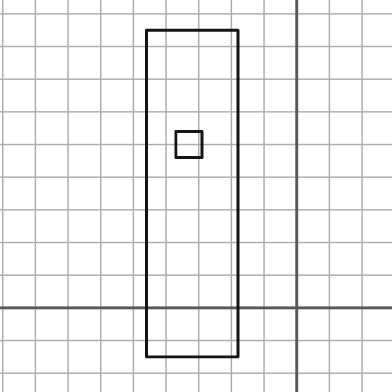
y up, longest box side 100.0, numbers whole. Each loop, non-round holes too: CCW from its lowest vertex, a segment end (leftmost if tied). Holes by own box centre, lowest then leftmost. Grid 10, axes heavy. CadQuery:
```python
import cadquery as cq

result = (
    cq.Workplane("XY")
    .moveTo(-46.0, -15.0)
    .lineTo(-18.0, -15.0)
    .lineTo(-18.0, 85.0)
    .lineTo(-46.0, 85.0)
    .close()
    .moveTo(-37.0, 46.0)
    .lineTo(-29.0, 46.0)
    .lineTo(-29.0, 54.0)
    .lineTo(-37.0, 54.0)
    .close()
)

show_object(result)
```